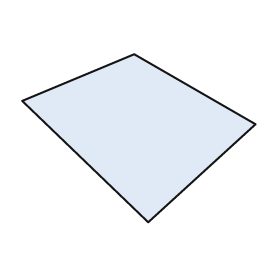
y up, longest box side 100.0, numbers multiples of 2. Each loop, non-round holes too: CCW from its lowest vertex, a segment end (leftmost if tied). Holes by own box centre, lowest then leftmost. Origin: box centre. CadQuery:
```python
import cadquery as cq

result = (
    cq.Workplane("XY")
    .moveTo(4.0, -36.0)
    .lineTo(50.0, 6.0)
    .lineTo(-2.0, 36.0)
    .lineTo(-50.0, 16.0)
    .close()
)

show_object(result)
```